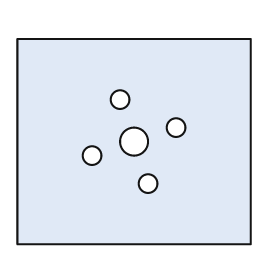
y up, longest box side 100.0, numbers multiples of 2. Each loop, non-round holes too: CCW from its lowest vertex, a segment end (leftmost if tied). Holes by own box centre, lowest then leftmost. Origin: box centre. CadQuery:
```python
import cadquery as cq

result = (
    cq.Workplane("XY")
    .moveTo(-50.0, -44.0)
    .lineTo(50.0, -44.0)
    .lineTo(50.0, 44.0)
    .lineTo(-50.0, 44.0)
    .close()
    .moveTo(6.0, -18.0)
    .circle(4.0)
    .moveTo(-18.0, -6.0)
    .circle(4.0)
    .moveTo(0.0, 0.0)
    .circle(6.0)
    .moveTo(18.0, 6.0)
    .circle(4.0)
    .moveTo(-6.0, 18.0)
    .circle(4.0)
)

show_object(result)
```